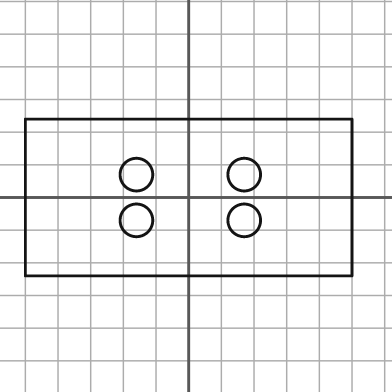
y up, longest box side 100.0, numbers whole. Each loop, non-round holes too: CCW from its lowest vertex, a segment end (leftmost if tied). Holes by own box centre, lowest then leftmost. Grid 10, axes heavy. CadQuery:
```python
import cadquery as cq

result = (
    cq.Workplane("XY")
    .moveTo(-50.0, -24.0)
    .lineTo(50.0, -24.0)
    .lineTo(50.0, 24.0)
    .lineTo(-50.0, 24.0)
    .close()
    .moveTo(-16.0, -7.0)
    .circle(5.0)
    .moveTo(17.0, -7.0)
    .circle(5.0)
    .moveTo(-16.0, 7.0)
    .circle(5.0)
    .moveTo(17.0, 7.0)
    .circle(5.0)
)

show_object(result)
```